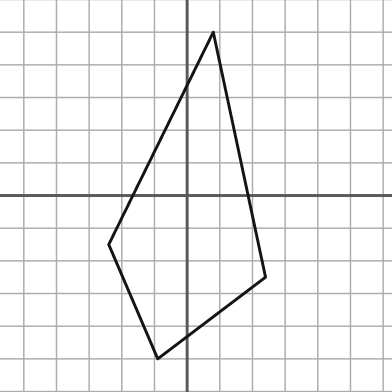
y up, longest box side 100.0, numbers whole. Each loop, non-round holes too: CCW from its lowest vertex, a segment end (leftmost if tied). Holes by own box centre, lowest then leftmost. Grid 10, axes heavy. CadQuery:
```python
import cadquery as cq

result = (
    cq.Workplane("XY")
    .moveTo(-9.0, -50.0)
    .lineTo(24.0, -25.0)
    .lineTo(8.0, 50.0)
    .lineTo(-24.0, -15.0)
    .close()
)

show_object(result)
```